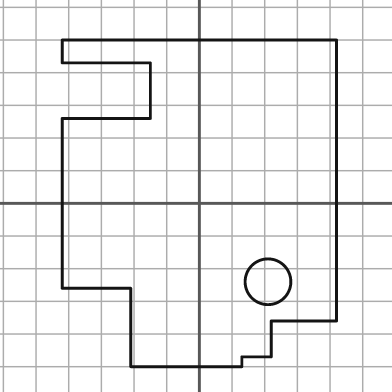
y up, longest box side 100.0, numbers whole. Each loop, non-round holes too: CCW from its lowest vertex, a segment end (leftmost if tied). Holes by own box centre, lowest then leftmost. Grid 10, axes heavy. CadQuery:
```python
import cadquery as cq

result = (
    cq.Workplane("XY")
    .moveTo(-21.0, -50.0)
    .lineTo(13.0, -50.0)
    .lineTo(13.0, -47.0)
    .lineTo(22.0, -47.0)
    .lineTo(22.0, -36.0)
    .lineTo(42.0, -36.0)
    .lineTo(42.0, 50.0)
    .lineTo(-42.0, 50.0)
    .lineTo(-42.0, 43.0)
    .lineTo(-15.0, 43.0)
    .lineTo(-15.0, 26.0)
    .lineTo(-42.0, 26.0)
    .lineTo(-42.0, -26.0)
    .lineTo(-21.0, -26.0)
    .close()
    .moveTo(21.0, -24.0)
    .circle(7.0)
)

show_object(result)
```